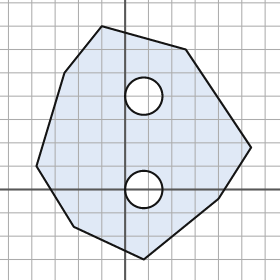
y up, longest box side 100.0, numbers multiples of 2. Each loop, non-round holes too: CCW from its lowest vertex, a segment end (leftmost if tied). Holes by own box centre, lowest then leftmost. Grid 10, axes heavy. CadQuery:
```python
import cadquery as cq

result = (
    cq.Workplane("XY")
    .moveTo(8.0, -30.0)
    .lineTo(40.0, -4.0)
    .lineTo(54.0, 18.0)
    .lineTo(26.0, 60.0)
    .lineTo(-10.0, 70.0)
    .lineTo(-26.0, 50.0)
    .lineTo(-38.0, 10.0)
    .lineTo(-22.0, -16.0)
    .close()
    .moveTo(8.0, 0.0)
    .circle(8.0)
    .moveTo(8.0, 40.0)
    .circle(8.0)
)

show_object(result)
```